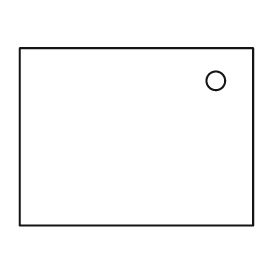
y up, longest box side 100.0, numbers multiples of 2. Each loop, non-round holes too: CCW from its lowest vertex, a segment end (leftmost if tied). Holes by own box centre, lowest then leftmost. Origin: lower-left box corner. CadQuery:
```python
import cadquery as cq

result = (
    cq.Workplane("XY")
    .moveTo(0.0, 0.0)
    .lineTo(100.0, 0.0)
    .lineTo(100.0, 76.0)
    .lineTo(0.0, 76.0)
    .close()
    .moveTo(84.0, 62.0)
    .circle(4.0)
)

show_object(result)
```